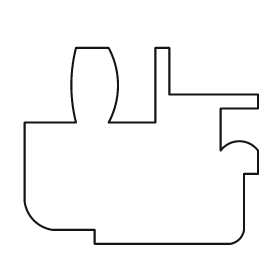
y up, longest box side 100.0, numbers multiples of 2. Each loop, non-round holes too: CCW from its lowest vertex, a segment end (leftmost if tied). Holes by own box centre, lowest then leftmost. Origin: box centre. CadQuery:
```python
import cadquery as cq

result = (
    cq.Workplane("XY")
    .moveTo(-20.0, -42.0)
    .lineTo(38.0, -42.0)
    .threePointArc((42.0, -40.0), (44.0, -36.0))
    .lineTo(44.0, -12.0)
    .lineTo(50.0, -12.0)
    .lineTo(50.0, -2.0)
    .threePointArc((42.0, 2.0), (34.0, -2.0))
    .lineTo(34.0, 16.0)
    .lineTo(50.0, 16.0)
    .lineTo(50.0, 22.0)
    .lineTo(12.0, 22.0)
    .lineTo(12.0, 42.0)
    .lineTo(6.0, 42.0)
    .lineTo(6.0, 10.0)
    .lineTo(-14.0, 10.0)
    .threePointArc((-10.0, 26.0), (-14.0, 42.0))
    .lineTo(-28.0, 42.0)
    .threePointArc((-30.0, 26.0), (-28.0, 10.0))
    .lineTo(-50.0, 10.0)
    .lineTo(-50.0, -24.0)
    .threePointArc((-46.0, -32.0), (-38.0, -36.0))
    .lineTo(-20.0, -36.0)
    .close()
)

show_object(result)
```